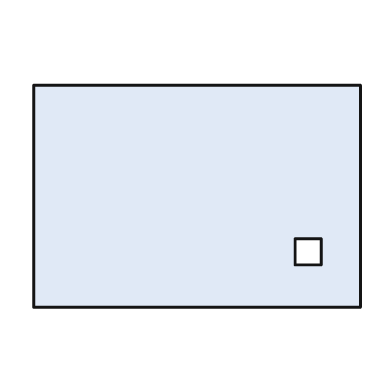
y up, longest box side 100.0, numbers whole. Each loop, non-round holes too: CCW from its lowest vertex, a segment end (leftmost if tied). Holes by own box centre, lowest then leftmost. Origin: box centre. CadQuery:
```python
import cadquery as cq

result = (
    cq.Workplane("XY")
    .moveTo(-50.0, -34.0)
    .lineTo(50.0, -34.0)
    .lineTo(50.0, 34.0)
    .lineTo(-50.0, 34.0)
    .close()
    .moveTo(30.0, -21.0)
    .lineTo(38.0, -21.0)
    .lineTo(38.0, -13.0)
    .lineTo(30.0, -13.0)
    .close()
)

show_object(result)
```